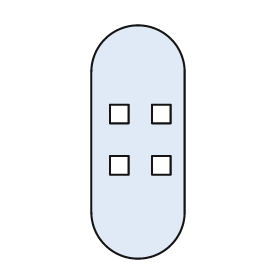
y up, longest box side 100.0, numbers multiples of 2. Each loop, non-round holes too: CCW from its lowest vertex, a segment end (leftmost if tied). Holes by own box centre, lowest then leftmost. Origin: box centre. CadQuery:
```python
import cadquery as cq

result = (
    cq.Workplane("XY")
    .moveTo(-20.0, -30.0)
    .threePointArc((0.0, -50.0), (20.0, -30.0))
    .lineTo(20.0, 30.0)
    .threePointArc((0.0, 50.0), (-20.0, 30.0))
    .close()
    .moveTo(-12.0, -14.0)
    .lineTo(-4.0, -14.0)
    .lineTo(-4.0, -6.0)
    .lineTo(-12.0, -6.0)
    .close()
    .moveTo(6.0, -14.0)
    .lineTo(14.0, -14.0)
    .lineTo(14.0, -6.0)
    .lineTo(6.0, -6.0)
    .close()
    .moveTo(-12.0, 8.0)
    .lineTo(-4.0, 8.0)
    .lineTo(-4.0, 16.0)
    .lineTo(-12.0, 16.0)
    .close()
    .moveTo(6.0, 8.0)
    .lineTo(14.0, 8.0)
    .lineTo(14.0, 16.0)
    .lineTo(6.0, 16.0)
    .close()
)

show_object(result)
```